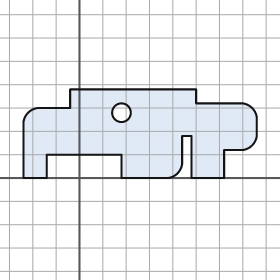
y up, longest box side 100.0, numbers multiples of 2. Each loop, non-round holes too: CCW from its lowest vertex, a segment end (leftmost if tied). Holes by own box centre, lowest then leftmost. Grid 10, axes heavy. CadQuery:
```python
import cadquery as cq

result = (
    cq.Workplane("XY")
    .moveTo(-24.0, 0.0)
    .lineTo(-14.0, 0.0)
    .lineTo(-14.0, 10.0)
    .lineTo(18.0, 10.0)
    .lineTo(18.0, 0.0)
    .lineTo(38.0, 0.0)
    .threePointArc((42.0, 2.0), (44.0, 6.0))
    .lineTo(44.0, 18.0)
    .lineTo(48.0, 18.0)
    .lineTo(48.0, 0.0)
    .lineTo(62.0, 0.0)
    .lineTo(62.0, 12.0)
    .lineTo(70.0, 12.0)
    .threePointArc((74.0, 14.0), (76.0, 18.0))
    .lineTo(76.0, 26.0)
    .threePointArc((74.0, 30.0), (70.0, 32.0))
    .lineTo(50.0, 32.0)
    .lineTo(50.0, 38.0)
    .lineTo(-4.0, 38.0)
    .lineTo(-4.0, 30.0)
    .lineTo(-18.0, 30.0)
    .threePointArc((-22.0, 28.0), (-24.0, 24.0))
    .close()
    .moveTo(18.0, 28.0)
    .circle(4.0)
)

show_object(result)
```